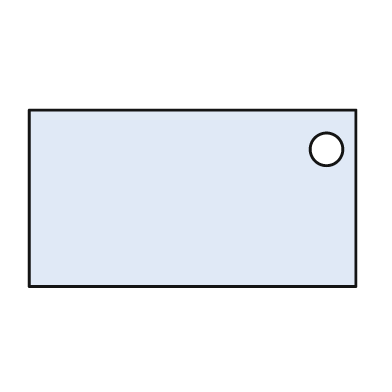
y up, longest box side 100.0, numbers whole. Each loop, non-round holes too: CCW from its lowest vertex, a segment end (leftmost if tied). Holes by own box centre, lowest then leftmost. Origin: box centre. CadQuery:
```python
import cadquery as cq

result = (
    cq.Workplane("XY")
    .moveTo(-50.0, -27.0)
    .lineTo(50.0, -27.0)
    .lineTo(50.0, 27.0)
    .lineTo(-50.0, 27.0)
    .close()
    .moveTo(41.0, 15.0)
    .circle(5.0)
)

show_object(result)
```